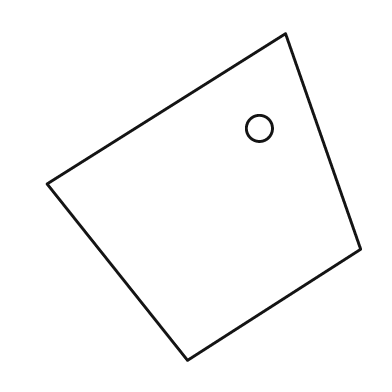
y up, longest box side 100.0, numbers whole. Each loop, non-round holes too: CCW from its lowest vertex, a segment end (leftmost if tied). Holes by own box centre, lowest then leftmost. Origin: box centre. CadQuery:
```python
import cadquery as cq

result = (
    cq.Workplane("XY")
    .moveTo(-5.0, -50.0)
    .lineTo(48.0, -16.0)
    .lineTo(25.0, 50.0)
    .lineTo(-48.0, 4.0)
    .close()
    .moveTo(17.0, 21.0)
    .circle(4.0)
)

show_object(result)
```